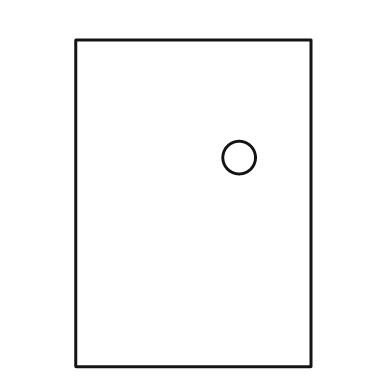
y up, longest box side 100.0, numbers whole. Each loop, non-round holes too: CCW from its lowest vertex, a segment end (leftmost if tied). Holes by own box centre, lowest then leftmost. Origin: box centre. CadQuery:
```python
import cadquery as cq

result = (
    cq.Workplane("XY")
    .moveTo(-36.0, -50.0)
    .lineTo(36.0, -50.0)
    .lineTo(36.0, 50.0)
    .lineTo(-36.0, 50.0)
    .close()
    .moveTo(14.0, 14.0)
    .circle(5.0)
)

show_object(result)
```